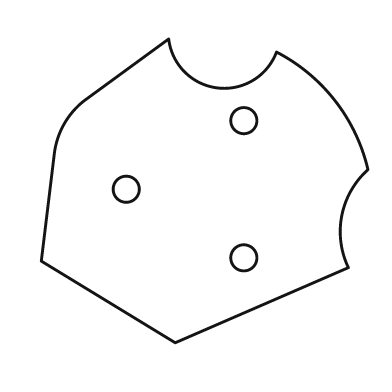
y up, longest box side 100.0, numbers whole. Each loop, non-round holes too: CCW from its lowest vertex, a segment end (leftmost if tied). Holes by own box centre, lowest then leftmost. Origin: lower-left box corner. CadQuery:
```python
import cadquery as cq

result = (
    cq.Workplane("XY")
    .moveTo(41.0, 0.0)
    .lineTo(94.0, 23.0)
    .threePointArc((92.0, 39.0), (100.0, 53.0))
    .threePointArc((90.0, 74.0), (72.0, 89.0))
    .threePointArc((54.0, 78.0), (39.0, 93.0))
    .lineTo(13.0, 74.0)
    .threePointArc((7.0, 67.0), (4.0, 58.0))
    .lineTo(0.0, 25.0)
    .close()
    .moveTo(62.0, 26.0)
    .circle(4.0)
    .moveTo(26.0, 47.0)
    .circle(4.0)
    .moveTo(62.0, 68.0)
    .circle(4.0)
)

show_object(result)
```